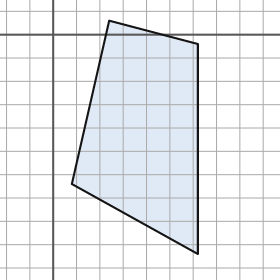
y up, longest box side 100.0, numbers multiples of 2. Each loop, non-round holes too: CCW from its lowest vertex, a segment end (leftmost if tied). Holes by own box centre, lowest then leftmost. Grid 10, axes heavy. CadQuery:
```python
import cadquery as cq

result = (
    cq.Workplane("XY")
    .moveTo(62.0, -94.0)
    .lineTo(62.0, -4.0)
    .lineTo(24.0, 6.0)
    .lineTo(8.0, -64.0)
    .close()
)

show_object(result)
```